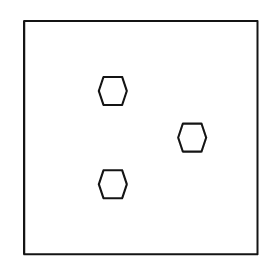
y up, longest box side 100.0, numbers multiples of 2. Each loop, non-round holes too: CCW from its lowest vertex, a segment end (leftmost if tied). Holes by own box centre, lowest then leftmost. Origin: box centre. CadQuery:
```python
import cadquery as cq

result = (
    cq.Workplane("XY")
    .moveTo(-50.0, -50.0)
    .lineTo(50.0, -50.0)
    .lineTo(50.0, 50.0)
    .lineTo(-50.0, 50.0)
    .close()
    .moveTo(-16.0, -26.0)
    .lineTo(-8.0, -26.0)
    .lineTo(-6.0, -20.0)
    .lineTo(-8.0, -14.0)
    .lineTo(-16.0, -14.0)
    .lineTo(-18.0, -20.0)
    .close()
    .moveTo(18.0, -6.0)
    .lineTo(26.0, -6.0)
    .lineTo(28.0, 0.0)
    .lineTo(26.0, 6.0)
    .lineTo(18.0, 6.0)
    .lineTo(16.0, 0.0)
    .close()
    .moveTo(-16.0, 14.0)
    .lineTo(-8.0, 14.0)
    .lineTo(-6.0, 20.0)
    .lineTo(-8.0, 26.0)
    .lineTo(-16.0, 26.0)
    .lineTo(-18.0, 20.0)
    .close()
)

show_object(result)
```